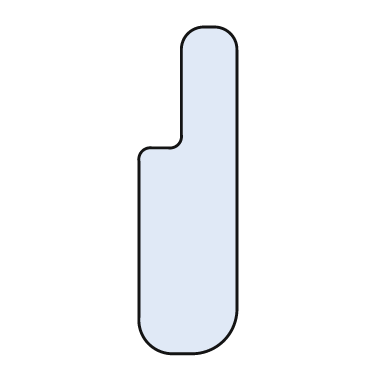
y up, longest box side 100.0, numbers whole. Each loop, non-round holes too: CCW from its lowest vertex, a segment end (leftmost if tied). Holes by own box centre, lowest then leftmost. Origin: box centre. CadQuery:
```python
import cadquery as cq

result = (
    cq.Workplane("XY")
    .moveTo(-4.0, -50.0)
    .lineTo(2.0, -50.0)
    .threePointArc((11.0, -46.0), (15.0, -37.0))
    .lineTo(15.0, 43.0)
    .threePointArc((13.0, 48.0), (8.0, 50.0))
    .lineTo(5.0, 50.0)
    .threePointArc((0.0, 48.0), (-2.0, 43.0))
    .lineTo(-2.0, 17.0)
    .threePointArc((-3.0, 14.0), (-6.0, 13.0))
    .lineTo(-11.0, 13.0)
    .threePointArc((-14.0, 12.0), (-15.0, 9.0))
    .lineTo(-15.0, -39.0)
    .threePointArc((-12.0, -47.0), (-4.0, -50.0))
    .close()
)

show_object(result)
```